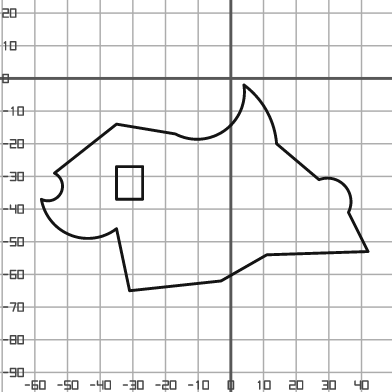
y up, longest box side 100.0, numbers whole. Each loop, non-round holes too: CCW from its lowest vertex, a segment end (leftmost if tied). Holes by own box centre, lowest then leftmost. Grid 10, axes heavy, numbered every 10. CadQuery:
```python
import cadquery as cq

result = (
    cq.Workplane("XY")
    .moveTo(-31.0, -65.0)
    .lineTo(-3.0, -62.0)
    .lineTo(11.0, -54.0)
    .lineTo(42.0, -53.0)
    .lineTo(36.0, -41.0)
    .threePointArc((35.0, -33.0), (27.0, -31.0))
    .lineTo(14.0, -20.0)
    .threePointArc((11.0, -10.0), (4.0, -2.0))
    .threePointArc((-2.0, -16.0), (-17.0, -17.0))
    .lineTo(-35.0, -14.0)
    .lineTo(-54.0, -29.0)
    .threePointArc((-52.0, -35.0), (-58.0, -37.0))
    .threePointArc((-49.0, -48.0), (-35.0, -46.0))
    .close()
    .moveTo(-35.0, -37.0)
    .lineTo(-27.0, -37.0)
    .lineTo(-27.0, -27.0)
    .lineTo(-35.0, -27.0)
    .close()
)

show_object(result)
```